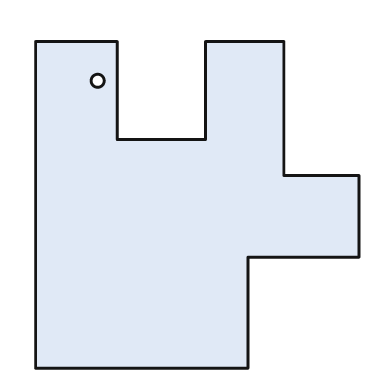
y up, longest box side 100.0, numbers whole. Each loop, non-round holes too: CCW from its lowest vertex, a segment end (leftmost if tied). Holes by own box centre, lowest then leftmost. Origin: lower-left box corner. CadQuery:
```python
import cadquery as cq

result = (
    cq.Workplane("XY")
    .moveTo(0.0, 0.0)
    .lineTo(65.0, 0.0)
    .lineTo(65.0, 34.0)
    .lineTo(99.0, 34.0)
    .lineTo(99.0, 59.0)
    .lineTo(76.0, 59.0)
    .lineTo(76.0, 100.0)
    .lineTo(52.0, 100.0)
    .lineTo(52.0, 70.0)
    .lineTo(25.0, 70.0)
    .lineTo(25.0, 100.0)
    .lineTo(0.0, 100.0)
    .close()
    .moveTo(19.0, 88.0)
    .circle(2.0)
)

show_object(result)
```